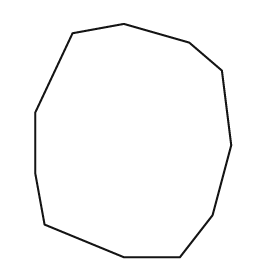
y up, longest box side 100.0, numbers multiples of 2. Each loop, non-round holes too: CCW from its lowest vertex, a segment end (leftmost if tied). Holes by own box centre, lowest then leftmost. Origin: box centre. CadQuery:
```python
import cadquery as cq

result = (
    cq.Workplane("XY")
    .moveTo(-4.0, -50.0)
    .lineTo(20.0, -50.0)
    .lineTo(34.0, -32.0)
    .lineTo(42.0, -2.0)
    .lineTo(38.0, 30.0)
    .lineTo(24.0, 42.0)
    .lineTo(-4.0, 50.0)
    .lineTo(-26.0, 46.0)
    .lineTo(-42.0, 12.0)
    .lineTo(-42.0, -14.0)
    .lineTo(-38.0, -36.0)
    .close()
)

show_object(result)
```